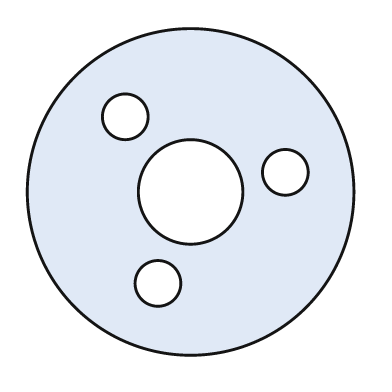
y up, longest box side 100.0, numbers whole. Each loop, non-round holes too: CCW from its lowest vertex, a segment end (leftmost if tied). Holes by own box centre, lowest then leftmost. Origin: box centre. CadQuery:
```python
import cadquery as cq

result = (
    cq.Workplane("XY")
    .moveTo(0.0, 0.0)
    .circle(50.0)
    .moveTo(-10.0, -28.0)
    .circle(7.0)
    .moveTo(0.0, 0.0)
    .circle(16.0)
    .moveTo(29.0, 6.0)
    .circle(7.0)
    .moveTo(-20.0, 23.0)
    .circle(7.0)
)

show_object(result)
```